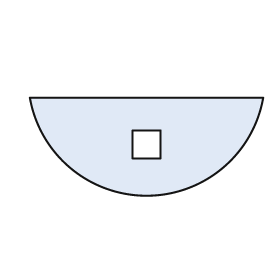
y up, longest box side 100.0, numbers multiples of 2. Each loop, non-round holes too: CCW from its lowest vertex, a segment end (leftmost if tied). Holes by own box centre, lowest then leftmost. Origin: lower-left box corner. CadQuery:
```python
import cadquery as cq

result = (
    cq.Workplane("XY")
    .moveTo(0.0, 42.0)
    .threePointArc((50.0, 0.0), (100.0, 42.0))
    .close()
    .moveTo(44.0, 16.0)
    .lineTo(56.0, 16.0)
    .lineTo(56.0, 28.0)
    .lineTo(44.0, 28.0)
    .close()
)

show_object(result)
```